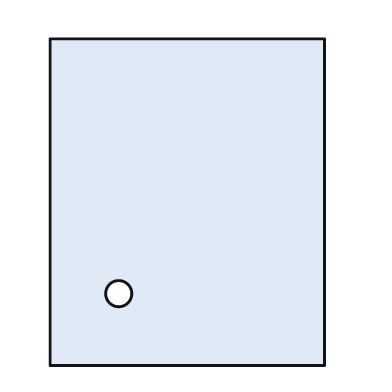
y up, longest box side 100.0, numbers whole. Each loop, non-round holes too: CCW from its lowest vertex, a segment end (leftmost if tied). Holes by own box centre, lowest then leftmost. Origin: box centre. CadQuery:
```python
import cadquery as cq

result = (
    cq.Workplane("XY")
    .moveTo(-42.0, -50.0)
    .lineTo(42.0, -50.0)
    .lineTo(42.0, 50.0)
    .lineTo(-42.0, 50.0)
    .close()
    .moveTo(-21.0, -28.0)
    .circle(4.0)
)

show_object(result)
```